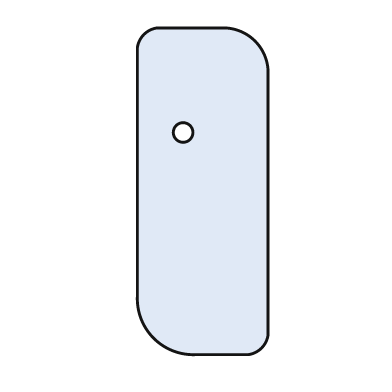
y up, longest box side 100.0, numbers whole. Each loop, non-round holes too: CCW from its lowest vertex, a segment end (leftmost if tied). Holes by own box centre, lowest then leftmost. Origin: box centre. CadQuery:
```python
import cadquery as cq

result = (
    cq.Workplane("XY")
    .moveTo(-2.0, -50.0)
    .lineTo(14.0, -50.0)
    .threePointArc((18.0, -48.0), (20.0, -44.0))
    .lineTo(20.0, 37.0)
    .threePointArc((16.0, 46.0), (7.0, 50.0))
    .lineTo(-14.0, 50.0)
    .threePointArc((-18.0, 48.0), (-20.0, 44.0))
    .lineTo(-20.0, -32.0)
    .threePointArc((-15.0, -45.0), (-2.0, -50.0))
    .close()
    .moveTo(-6.0, 18.0)
    .circle(3.0)
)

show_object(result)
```